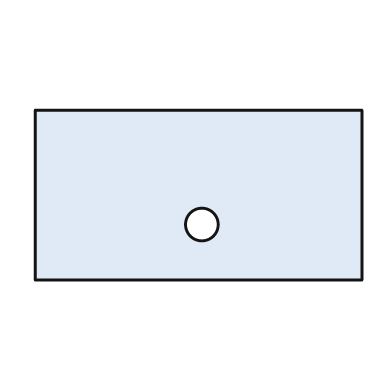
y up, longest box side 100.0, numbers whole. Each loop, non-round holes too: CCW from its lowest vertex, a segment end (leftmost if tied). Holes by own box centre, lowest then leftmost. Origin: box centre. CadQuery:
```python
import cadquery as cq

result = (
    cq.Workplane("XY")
    .moveTo(-50.0, -26.0)
    .lineTo(50.0, -26.0)
    .lineTo(50.0, 26.0)
    .lineTo(-50.0, 26.0)
    .close()
    .moveTo(1.0, -9.0)
    .circle(5.0)
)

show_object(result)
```